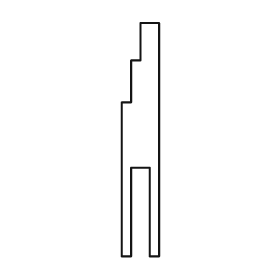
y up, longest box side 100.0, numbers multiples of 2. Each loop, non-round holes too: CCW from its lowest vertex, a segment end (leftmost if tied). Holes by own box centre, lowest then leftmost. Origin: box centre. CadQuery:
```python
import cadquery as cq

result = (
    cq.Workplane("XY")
    .moveTo(-8.0, -50.0)
    .lineTo(-4.0, -50.0)
    .lineTo(-4.0, -12.0)
    .lineTo(4.0, -12.0)
    .lineTo(4.0, -50.0)
    .lineTo(8.0, -50.0)
    .lineTo(8.0, 50.0)
    .lineTo(0.0, 50.0)
    .lineTo(0.0, 34.0)
    .lineTo(-4.0, 34.0)
    .lineTo(-4.0, 16.0)
    .lineTo(-8.0, 16.0)
    .close()
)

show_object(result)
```